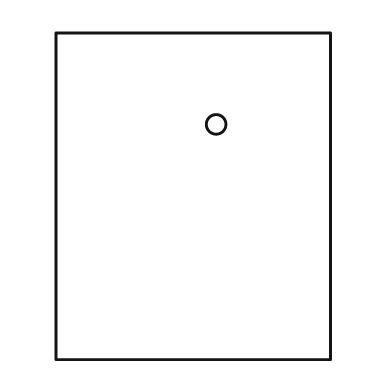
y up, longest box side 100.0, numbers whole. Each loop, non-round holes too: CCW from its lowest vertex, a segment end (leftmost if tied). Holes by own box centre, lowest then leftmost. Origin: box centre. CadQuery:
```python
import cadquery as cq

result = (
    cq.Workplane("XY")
    .moveTo(-42.0, -50.0)
    .lineTo(42.0, -50.0)
    .lineTo(42.0, 50.0)
    .lineTo(-42.0, 50.0)
    .close()
    .moveTo(7.0, 22.0)
    .circle(3.0)
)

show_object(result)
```